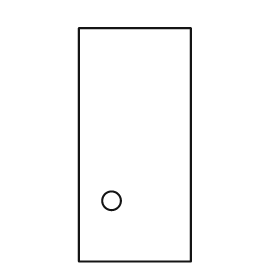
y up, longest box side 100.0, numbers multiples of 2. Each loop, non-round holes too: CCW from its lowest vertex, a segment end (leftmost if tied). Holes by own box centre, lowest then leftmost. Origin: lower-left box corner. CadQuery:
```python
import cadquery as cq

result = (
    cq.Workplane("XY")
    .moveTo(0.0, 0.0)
    .lineTo(48.0, 0.0)
    .lineTo(48.0, 100.0)
    .lineTo(0.0, 100.0)
    .close()
    .moveTo(14.0, 26.0)
    .circle(4.0)
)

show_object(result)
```